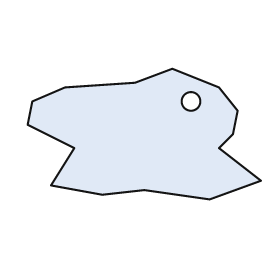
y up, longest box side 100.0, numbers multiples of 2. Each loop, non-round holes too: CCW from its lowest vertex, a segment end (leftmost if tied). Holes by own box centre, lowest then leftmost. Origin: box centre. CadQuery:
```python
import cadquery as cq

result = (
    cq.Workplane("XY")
    .moveTo(28.0, -28.0)
    .lineTo(50.0, -20.0)
    .lineTo(32.0, -6.0)
    .lineTo(38.0, 0.0)
    .lineTo(40.0, 10.0)
    .lineTo(32.0, 20.0)
    .lineTo(12.0, 28.0)
    .lineTo(-4.0, 22.0)
    .lineTo(-34.0, 20.0)
    .lineTo(-48.0, 14.0)
    .lineTo(-50.0, 4.0)
    .lineTo(-30.0, -6.0)
    .lineTo(-40.0, -22.0)
    .lineTo(-18.0, -26.0)
    .lineTo(0.0, -24.0)
    .close()
    .moveTo(20.0, 14.0)
    .circle(4.0)
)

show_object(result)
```